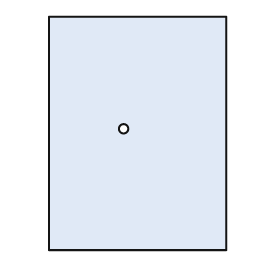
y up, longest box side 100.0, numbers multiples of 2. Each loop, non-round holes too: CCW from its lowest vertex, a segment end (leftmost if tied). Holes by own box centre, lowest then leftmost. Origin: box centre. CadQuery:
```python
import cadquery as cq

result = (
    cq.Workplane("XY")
    .moveTo(-38.0, -50.0)
    .lineTo(38.0, -50.0)
    .lineTo(38.0, 50.0)
    .lineTo(-38.0, 50.0)
    .close()
    .moveTo(-6.0, 2.0)
    .circle(2.0)
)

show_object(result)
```